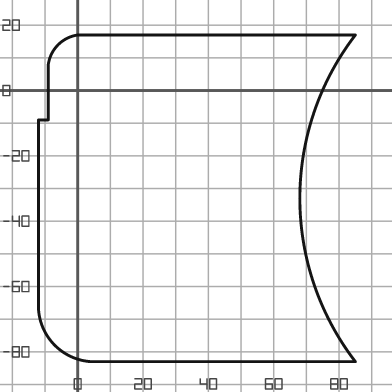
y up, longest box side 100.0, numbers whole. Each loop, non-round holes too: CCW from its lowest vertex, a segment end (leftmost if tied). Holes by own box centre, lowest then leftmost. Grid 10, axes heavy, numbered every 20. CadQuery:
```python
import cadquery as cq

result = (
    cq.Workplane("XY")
    .moveTo(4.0, -83.0)
    .lineTo(85.0, -83.0)
    .threePointArc((68.0, -33.0), (85.0, 17.0))
    .lineTo(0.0, 17.0)
    .threePointArc((-6.0, 14.0), (-9.0, 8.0))
    .lineTo(-9.0, -9.0)
    .lineTo(-12.0, -9.0)
    .lineTo(-12.0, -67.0)
    .threePointArc((-7.0, -78.0), (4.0, -83.0))
    .close()
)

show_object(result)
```